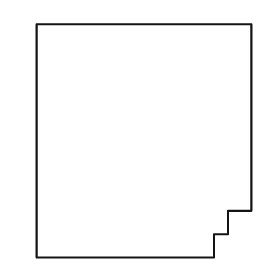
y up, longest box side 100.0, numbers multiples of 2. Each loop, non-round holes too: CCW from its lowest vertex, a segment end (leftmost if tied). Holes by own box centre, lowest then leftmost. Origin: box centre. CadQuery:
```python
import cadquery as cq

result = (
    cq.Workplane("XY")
    .moveTo(-46.0, -50.0)
    .lineTo(30.0, -50.0)
    .lineTo(30.0, -40.0)
    .lineTo(36.0, -40.0)
    .lineTo(36.0, -30.0)
    .lineTo(46.0, -30.0)
    .lineTo(46.0, 50.0)
    .lineTo(-46.0, 50.0)
    .close()
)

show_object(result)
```